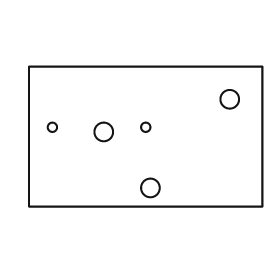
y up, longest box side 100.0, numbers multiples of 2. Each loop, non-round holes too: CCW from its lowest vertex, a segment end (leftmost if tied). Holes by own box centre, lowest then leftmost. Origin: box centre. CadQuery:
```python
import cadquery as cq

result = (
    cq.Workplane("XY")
    .moveTo(-50.0, -30.0)
    .lineTo(50.0, -30.0)
    .lineTo(50.0, 30.0)
    .lineTo(-50.0, 30.0)
    .close()
    .moveTo(2.0, -22.0)
    .circle(4.0)
    .moveTo(-18.0, 2.0)
    .circle(4.0)
    .moveTo(-40.0, 4.0)
    .circle(2.0)
    .moveTo(0.0, 4.0)
    .circle(2.0)
    .moveTo(36.0, 16.0)
    .circle(4.0)
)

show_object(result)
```